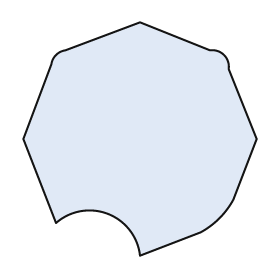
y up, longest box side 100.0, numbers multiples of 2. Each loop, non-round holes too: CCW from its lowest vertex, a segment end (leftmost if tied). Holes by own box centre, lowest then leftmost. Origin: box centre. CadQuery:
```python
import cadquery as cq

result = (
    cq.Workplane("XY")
    .moveTo(0.0, -50.0)
    .lineTo(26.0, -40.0)
    .threePointArc((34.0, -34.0), (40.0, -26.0))
    .lineTo(50.0, 0.0)
    .lineTo(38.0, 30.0)
    .threePointArc((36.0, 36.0), (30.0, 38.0))
    .lineTo(0.0, 50.0)
    .lineTo(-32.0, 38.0)
    .threePointArc((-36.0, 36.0), (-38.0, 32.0))
    .lineTo(-50.0, 0.0)
    .lineTo(-36.0, -36.0)
    .threePointArc((-14.0, -32.0), (0.0, -50.0))
    .close()
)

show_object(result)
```